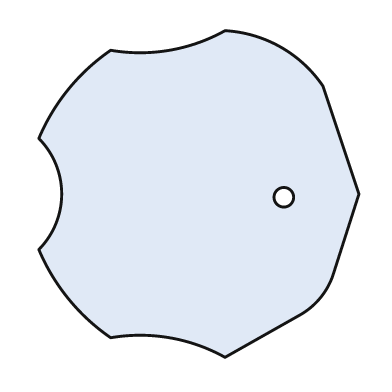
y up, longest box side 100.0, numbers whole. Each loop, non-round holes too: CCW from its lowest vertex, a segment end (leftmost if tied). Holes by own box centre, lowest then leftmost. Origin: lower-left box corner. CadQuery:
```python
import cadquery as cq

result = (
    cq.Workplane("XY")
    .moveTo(57.0, 0.0)
    .lineTo(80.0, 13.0)
    .threePointArc((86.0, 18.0), (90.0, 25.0))
    .lineTo(98.0, 50.0)
    .lineTo(87.0, 83.0)
    .threePointArc((74.0, 95.0), (57.0, 100.0))
    .threePointArc((40.0, 94.0), (22.0, 94.0))
    .threePointArc((9.0, 82.0), (0.0, 67.0))
    .threePointArc((7.0, 50.0), (0.0, 33.0))
    .threePointArc((9.0, 18.0), (22.0, 6.0))
    .threePointArc((40.0, 6.0), (57.0, 0.0))
    .close()
    .moveTo(75.0, 49.0)
    .circle(3.0)
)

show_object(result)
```